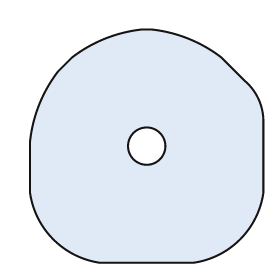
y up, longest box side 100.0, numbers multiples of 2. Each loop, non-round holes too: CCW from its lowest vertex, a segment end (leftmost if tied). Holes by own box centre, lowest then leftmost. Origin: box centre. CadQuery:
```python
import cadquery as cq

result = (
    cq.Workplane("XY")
    .moveTo(-20.0, -50.0)
    .lineTo(20.0, -50.0)
    .threePointArc((40.0, -40.0), (50.0, -20.0))
    .lineTo(50.0, 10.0)
    .threePointArc((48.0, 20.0), (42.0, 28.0))
    .lineTo(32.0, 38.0)
    .threePointArc((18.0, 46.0), (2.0, 50.0))
    .lineTo(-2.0, 50.0)
    .threePointArc((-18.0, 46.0), (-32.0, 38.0))
    .lineTo(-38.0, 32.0)
    .threePointArc((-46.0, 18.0), (-50.0, 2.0))
    .lineTo(-50.0, -20.0)
    .threePointArc((-40.0, -40.0), (-20.0, -50.0))
    .close()
    .moveTo(0.0, 0.0)
    .circle(8.0)
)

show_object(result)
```